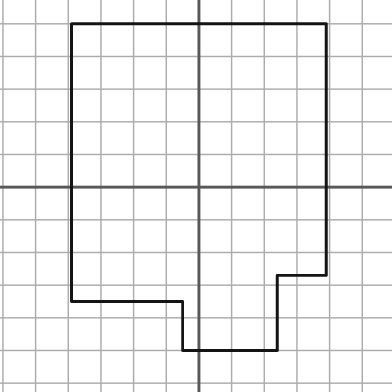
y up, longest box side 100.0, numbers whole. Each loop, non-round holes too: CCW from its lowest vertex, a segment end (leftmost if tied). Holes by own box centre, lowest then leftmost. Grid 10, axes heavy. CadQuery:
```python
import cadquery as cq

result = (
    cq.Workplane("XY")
    .moveTo(-5.0, -50.0)
    .lineTo(24.0, -50.0)
    .lineTo(24.0, -27.0)
    .lineTo(39.0, -27.0)
    .lineTo(39.0, 50.0)
    .lineTo(-39.0, 50.0)
    .lineTo(-39.0, -35.0)
    .lineTo(-5.0, -35.0)
    .close()
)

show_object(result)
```